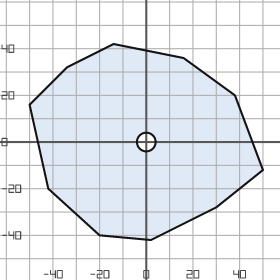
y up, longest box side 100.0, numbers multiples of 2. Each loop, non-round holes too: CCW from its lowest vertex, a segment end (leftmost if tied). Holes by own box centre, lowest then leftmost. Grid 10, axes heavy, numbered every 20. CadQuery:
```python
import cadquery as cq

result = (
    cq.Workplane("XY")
    .moveTo(2.0, -42.0)
    .lineTo(30.0, -28.0)
    .lineTo(50.0, -12.0)
    .lineTo(38.0, 20.0)
    .lineTo(16.0, 36.0)
    .lineTo(-14.0, 42.0)
    .lineTo(-34.0, 32.0)
    .lineTo(-50.0, 16.0)
    .lineTo(-42.0, -20.0)
    .lineTo(-20.0, -40.0)
    .close()
    .moveTo(0.0, 0.0)
    .circle(4.0)
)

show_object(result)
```